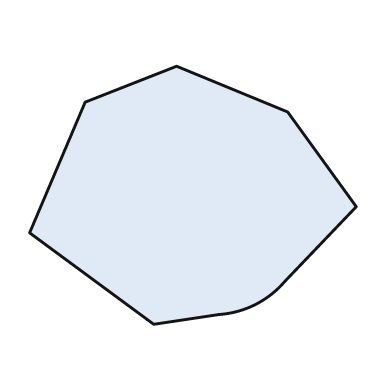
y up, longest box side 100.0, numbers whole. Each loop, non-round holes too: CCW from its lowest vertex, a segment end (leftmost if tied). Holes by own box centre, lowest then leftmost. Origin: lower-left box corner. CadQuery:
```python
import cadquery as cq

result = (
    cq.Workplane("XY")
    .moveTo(38.0, 0.0)
    .lineTo(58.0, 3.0)
    .threePointArc((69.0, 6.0), (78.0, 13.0))
    .lineTo(100.0, 36.0)
    .lineTo(79.0, 65.0)
    .lineTo(45.0, 79.0)
    .lineTo(17.0, 68.0)
    .lineTo(0.0, 28.0)
    .close()
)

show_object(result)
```